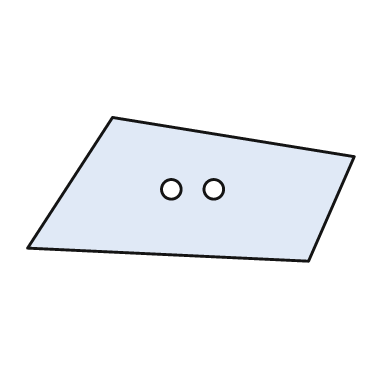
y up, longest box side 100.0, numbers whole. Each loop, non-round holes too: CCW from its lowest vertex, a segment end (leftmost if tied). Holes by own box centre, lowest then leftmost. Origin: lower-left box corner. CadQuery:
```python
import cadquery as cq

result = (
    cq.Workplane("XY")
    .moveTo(86.0, 0.0)
    .lineTo(100.0, 32.0)
    .lineTo(26.0, 44.0)
    .lineTo(0.0, 4.0)
    .close()
    .moveTo(44.0, 22.0)
    .circle(3.0)
    .moveTo(57.0, 22.0)
    .circle(3.0)
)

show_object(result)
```